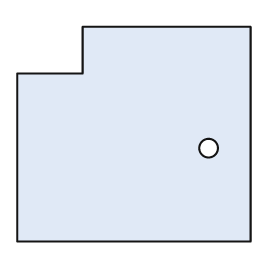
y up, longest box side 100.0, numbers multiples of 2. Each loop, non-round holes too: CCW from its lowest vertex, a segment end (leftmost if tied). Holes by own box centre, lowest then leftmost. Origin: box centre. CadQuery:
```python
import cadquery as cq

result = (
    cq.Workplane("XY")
    .moveTo(-50.0, -46.0)
    .lineTo(50.0, -46.0)
    .lineTo(50.0, 46.0)
    .lineTo(-22.0, 46.0)
    .lineTo(-22.0, 26.0)
    .lineTo(-50.0, 26.0)
    .close()
    .moveTo(32.0, -6.0)
    .circle(4.0)
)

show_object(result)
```